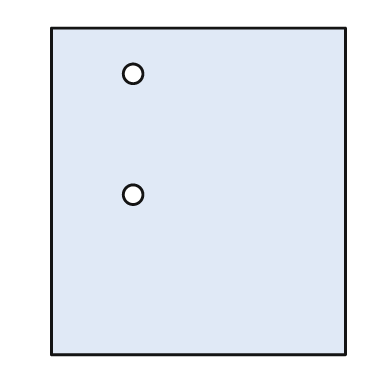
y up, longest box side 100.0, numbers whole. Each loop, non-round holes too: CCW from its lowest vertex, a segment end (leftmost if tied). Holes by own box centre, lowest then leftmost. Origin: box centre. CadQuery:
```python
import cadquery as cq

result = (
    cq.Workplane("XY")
    .moveTo(-45.0, -50.0)
    .lineTo(45.0, -50.0)
    .lineTo(45.0, 50.0)
    .lineTo(-45.0, 50.0)
    .close()
    .moveTo(-20.0, -1.0)
    .circle(3.0)
    .moveTo(-20.0, 36.0)
    .circle(3.0)
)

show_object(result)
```